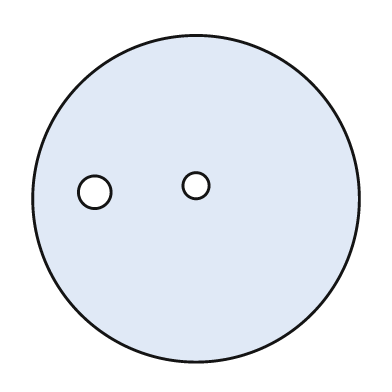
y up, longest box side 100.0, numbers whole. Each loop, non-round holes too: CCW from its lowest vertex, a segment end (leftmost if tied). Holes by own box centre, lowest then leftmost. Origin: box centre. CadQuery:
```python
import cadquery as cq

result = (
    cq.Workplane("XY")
    .moveTo(0.0, 0.0)
    .circle(50.0)
    .moveTo(-31.0, 2.0)
    .circle(5.0)
    .moveTo(0.0, 4.0)
    .circle(4.0)
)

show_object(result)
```